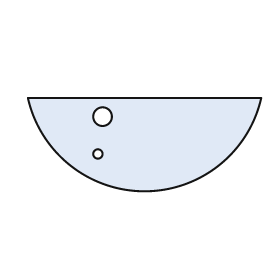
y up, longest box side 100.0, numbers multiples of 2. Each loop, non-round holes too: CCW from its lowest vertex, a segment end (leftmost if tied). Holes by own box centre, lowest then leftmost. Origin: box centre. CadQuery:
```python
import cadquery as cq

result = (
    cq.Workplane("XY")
    .moveTo(-50.0, 20.0)
    .threePointArc((0.0, -20.0), (50.0, 20.0))
    .close()
    .moveTo(-20.0, -4.0)
    .circle(2.0)
    .moveTo(-18.0, 12.0)
    .circle(4.0)
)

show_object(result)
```